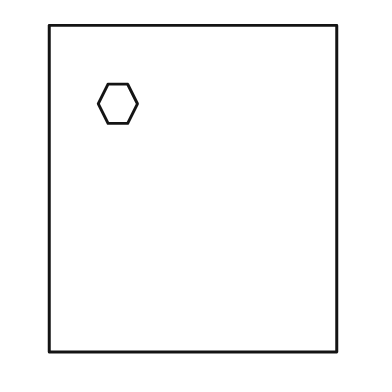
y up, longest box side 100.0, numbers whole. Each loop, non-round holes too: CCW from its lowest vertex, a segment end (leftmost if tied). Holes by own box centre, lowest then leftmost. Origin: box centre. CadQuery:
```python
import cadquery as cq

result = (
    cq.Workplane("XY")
    .moveTo(-44.0, -50.0)
    .lineTo(44.0, -50.0)
    .lineTo(44.0, 50.0)
    .lineTo(-44.0, 50.0)
    .close()
    .moveTo(-26.0, 20.0)
    .lineTo(-20.0, 20.0)
    .lineTo(-17.0, 26.0)
    .lineTo(-20.0, 32.0)
    .lineTo(-26.0, 32.0)
    .lineTo(-29.0, 26.0)
    .close()
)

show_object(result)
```